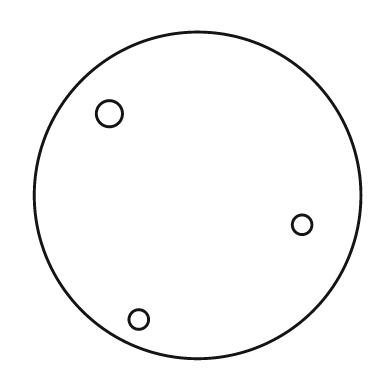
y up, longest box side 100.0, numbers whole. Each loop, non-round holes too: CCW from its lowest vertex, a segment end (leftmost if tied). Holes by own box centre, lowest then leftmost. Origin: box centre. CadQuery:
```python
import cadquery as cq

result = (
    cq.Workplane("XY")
    .moveTo(0.0, 0.0)
    .circle(50.0)
    .moveTo(-18.0, -38.0)
    .circle(3.0)
    .moveTo(32.0, -9.0)
    .circle(3.0)
    .moveTo(-27.0, 25.0)
    .circle(4.0)
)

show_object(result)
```